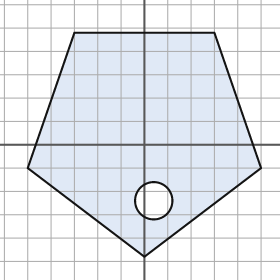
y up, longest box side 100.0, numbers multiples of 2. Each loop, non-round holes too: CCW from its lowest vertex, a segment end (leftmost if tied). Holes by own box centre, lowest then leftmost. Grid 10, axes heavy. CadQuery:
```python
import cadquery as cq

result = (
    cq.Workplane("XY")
    .moveTo(0.0, -48.0)
    .lineTo(50.0, -10.0)
    .lineTo(30.0, 48.0)
    .lineTo(-30.0, 48.0)
    .lineTo(-50.0, -10.0)
    .close()
    .moveTo(4.0, -24.0)
    .circle(8.0)
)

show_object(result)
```